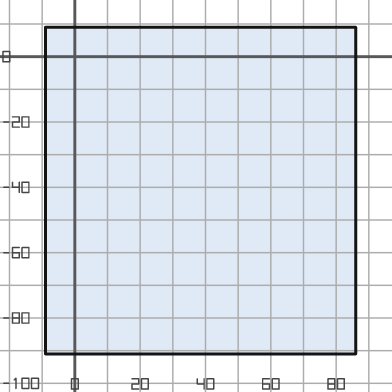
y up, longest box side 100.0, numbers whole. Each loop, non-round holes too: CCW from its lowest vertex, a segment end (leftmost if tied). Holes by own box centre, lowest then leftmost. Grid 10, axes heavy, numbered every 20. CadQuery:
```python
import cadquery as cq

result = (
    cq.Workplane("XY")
    .moveTo(-9.0, -91.0)
    .lineTo(86.0, -91.0)
    .lineTo(86.0, 9.0)
    .lineTo(-9.0, 9.0)
    .close()
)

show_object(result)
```